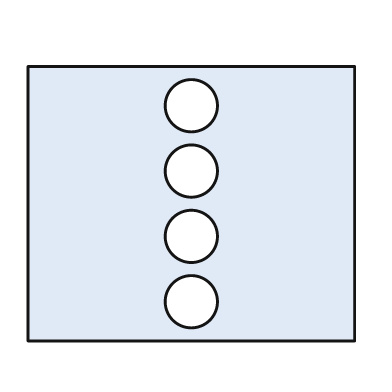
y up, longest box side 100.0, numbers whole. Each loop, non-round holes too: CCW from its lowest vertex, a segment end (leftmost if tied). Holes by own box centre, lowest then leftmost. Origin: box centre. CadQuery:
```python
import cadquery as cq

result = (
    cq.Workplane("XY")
    .moveTo(-50.0, -42.0)
    .lineTo(50.0, -42.0)
    .lineTo(50.0, 42.0)
    .lineTo(-50.0, 42.0)
    .close()
    .moveTo(0.0, -30.0)
    .circle(8.0)
    .moveTo(0.0, -10.0)
    .circle(8.0)
    .moveTo(0.0, 10.0)
    .circle(8.0)
    .moveTo(0.0, 30.0)
    .circle(8.0)
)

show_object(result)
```